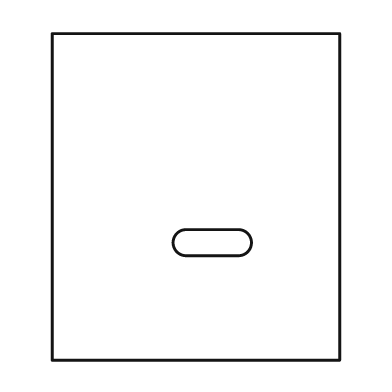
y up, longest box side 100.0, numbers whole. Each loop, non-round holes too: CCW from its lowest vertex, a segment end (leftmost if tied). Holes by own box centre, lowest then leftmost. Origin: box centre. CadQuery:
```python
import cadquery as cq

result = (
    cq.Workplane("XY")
    .moveTo(-44.0, -50.0)
    .lineTo(44.0, -50.0)
    .lineTo(44.0, 50.0)
    .lineTo(-44.0, 50.0)
    .close()
    .moveTo(-3.0, -18.0)
    .lineTo(13.0, -18.0)
    .threePointArc((17.0, -14.0), (13.0, -10.0))
    .lineTo(-3.0, -10.0)
    .threePointArc((-7.0, -14.0), (-3.0, -18.0))
    .close()
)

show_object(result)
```